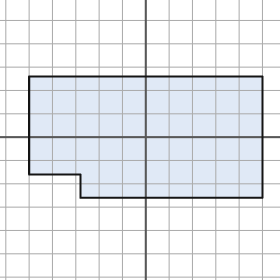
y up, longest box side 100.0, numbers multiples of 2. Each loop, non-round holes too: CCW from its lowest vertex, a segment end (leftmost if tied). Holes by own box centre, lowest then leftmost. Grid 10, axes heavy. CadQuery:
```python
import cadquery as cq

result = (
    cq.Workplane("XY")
    .moveTo(-28.0, -26.0)
    .lineTo(50.0, -26.0)
    .lineTo(50.0, 26.0)
    .lineTo(-50.0, 26.0)
    .lineTo(-50.0, -16.0)
    .lineTo(-28.0, -16.0)
    .close()
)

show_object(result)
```